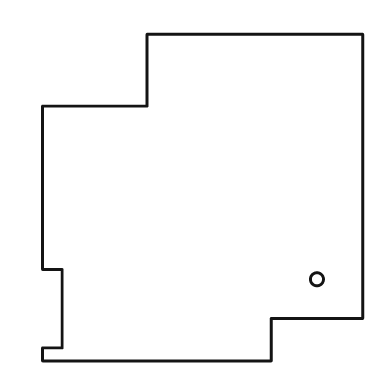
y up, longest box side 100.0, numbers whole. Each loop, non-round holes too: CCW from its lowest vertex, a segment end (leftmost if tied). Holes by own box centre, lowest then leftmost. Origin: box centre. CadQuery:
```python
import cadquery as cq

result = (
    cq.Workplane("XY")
    .moveTo(-49.0, -50.0)
    .lineTo(21.0, -50.0)
    .lineTo(21.0, -37.0)
    .lineTo(49.0, -37.0)
    .lineTo(49.0, 50.0)
    .lineTo(-17.0, 50.0)
    .lineTo(-17.0, 28.0)
    .lineTo(-49.0, 28.0)
    .lineTo(-49.0, -22.0)
    .lineTo(-43.0, -22.0)
    .lineTo(-43.0, -46.0)
    .lineTo(-49.0, -46.0)
    .close()
    .moveTo(35.0, -25.0)
    .circle(2.0)
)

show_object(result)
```